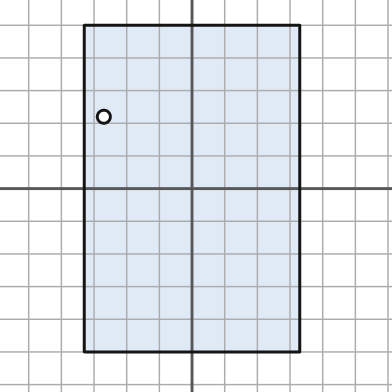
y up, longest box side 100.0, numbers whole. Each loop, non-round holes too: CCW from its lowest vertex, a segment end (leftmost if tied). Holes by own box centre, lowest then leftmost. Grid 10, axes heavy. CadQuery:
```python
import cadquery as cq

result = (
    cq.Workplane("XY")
    .moveTo(-33.0, -50.0)
    .lineTo(33.0, -50.0)
    .lineTo(33.0, 50.0)
    .lineTo(-33.0, 50.0)
    .close()
    .moveTo(-27.0, 22.0)
    .circle(2.0)
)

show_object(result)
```